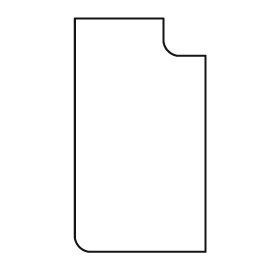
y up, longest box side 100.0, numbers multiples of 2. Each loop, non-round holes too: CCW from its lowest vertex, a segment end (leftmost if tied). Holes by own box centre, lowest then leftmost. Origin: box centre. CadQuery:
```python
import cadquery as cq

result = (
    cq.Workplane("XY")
    .moveTo(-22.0, -50.0)
    .lineTo(28.0, -50.0)
    .lineTo(28.0, 34.0)
    .lineTo(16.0, 34.0)
    .threePointArc((12.0, 36.0), (10.0, 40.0))
    .lineTo(10.0, 50.0)
    .lineTo(-28.0, 50.0)
    .lineTo(-28.0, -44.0)
    .threePointArc((-26.0, -48.0), (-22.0, -50.0))
    .close()
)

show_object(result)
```